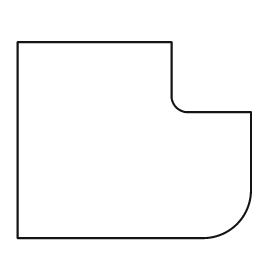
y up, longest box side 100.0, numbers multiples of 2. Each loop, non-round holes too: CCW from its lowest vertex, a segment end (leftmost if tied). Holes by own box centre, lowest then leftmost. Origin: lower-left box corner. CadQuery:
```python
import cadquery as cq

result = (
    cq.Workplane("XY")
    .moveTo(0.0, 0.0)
    .lineTo(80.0, 0.0)
    .threePointArc((94.0, 6.0), (100.0, 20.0))
    .lineTo(100.0, 54.0)
    .lineTo(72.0, 54.0)
    .threePointArc((68.0, 56.0), (66.0, 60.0))
    .lineTo(66.0, 84.0)
    .lineTo(0.0, 84.0)
    .close()
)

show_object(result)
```